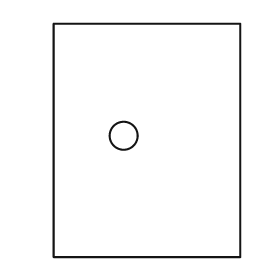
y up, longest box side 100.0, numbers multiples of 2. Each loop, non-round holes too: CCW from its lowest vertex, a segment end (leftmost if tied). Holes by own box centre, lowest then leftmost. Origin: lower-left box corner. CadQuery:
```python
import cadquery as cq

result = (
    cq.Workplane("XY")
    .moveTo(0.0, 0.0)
    .lineTo(80.0, 0.0)
    .lineTo(80.0, 100.0)
    .lineTo(0.0, 100.0)
    .close()
    .moveTo(30.0, 52.0)
    .circle(6.0)
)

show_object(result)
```